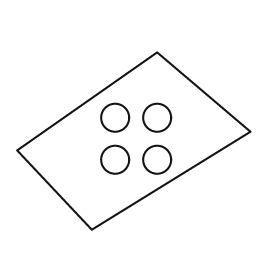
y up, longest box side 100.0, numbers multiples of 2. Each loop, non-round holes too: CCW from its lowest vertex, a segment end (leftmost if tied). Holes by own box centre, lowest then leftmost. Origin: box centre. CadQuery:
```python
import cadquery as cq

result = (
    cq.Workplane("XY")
    .moveTo(-18.0, -38.0)
    .lineTo(50.0, 4.0)
    .lineTo(10.0, 38.0)
    .lineTo(-50.0, -4.0)
    .close()
    .moveTo(-8.0, -8.0)
    .circle(6.0)
    .moveTo(10.0, -8.0)
    .circle(6.0)
    .moveTo(-8.0, 10.0)
    .circle(6.0)
    .moveTo(10.0, 10.0)
    .circle(6.0)
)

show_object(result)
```